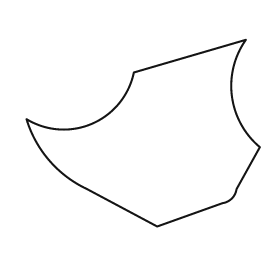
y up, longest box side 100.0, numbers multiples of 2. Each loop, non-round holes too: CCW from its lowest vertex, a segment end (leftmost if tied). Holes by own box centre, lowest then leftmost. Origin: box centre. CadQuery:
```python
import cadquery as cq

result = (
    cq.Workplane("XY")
    .moveTo(6.0, -40.0)
    .lineTo(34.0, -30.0)
    .threePointArc((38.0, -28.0), (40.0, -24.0))
    .lineTo(50.0, -6.0)
    .threePointArc((38.0, 16.0), (44.0, 40.0))
    .lineTo(-4.0, 26.0)
    .threePointArc((-22.0, 4.0), (-50.0, 6.0))
    .threePointArc((-40.0, -12.0), (-24.0, -24.0))
    .close()
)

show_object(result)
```